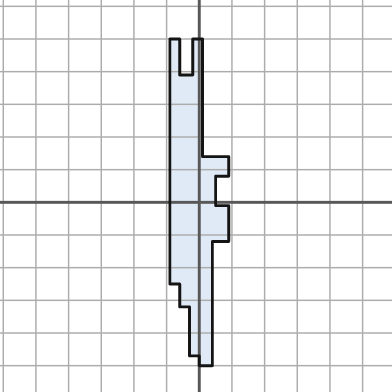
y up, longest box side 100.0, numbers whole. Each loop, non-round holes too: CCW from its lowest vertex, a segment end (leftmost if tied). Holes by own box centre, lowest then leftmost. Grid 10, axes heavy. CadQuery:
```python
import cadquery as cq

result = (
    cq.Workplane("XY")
    .moveTo(0.0, -50.0)
    .lineTo(4.0, -50.0)
    .lineTo(4.0, -12.0)
    .lineTo(9.0, -12.0)
    .lineTo(9.0, -1.0)
    .lineTo(5.0, -1.0)
    .lineTo(5.0, 8.0)
    .lineTo(9.0, 8.0)
    .lineTo(9.0, 14.0)
    .lineTo(1.0, 14.0)
    .lineTo(1.0, 50.0)
    .lineTo(-2.0, 50.0)
    .lineTo(-2.0, 39.0)
    .lineTo(-6.0, 39.0)
    .lineTo(-6.0, 50.0)
    .lineTo(-9.0, 50.0)
    .lineTo(-9.0, -25.0)
    .lineTo(-6.0, -25.0)
    .lineTo(-6.0, -32.0)
    .lineTo(-3.0, -32.0)
    .lineTo(-3.0, -47.0)
    .lineTo(0.0, -47.0)
    .close()
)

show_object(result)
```